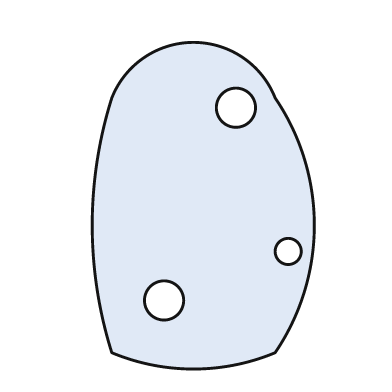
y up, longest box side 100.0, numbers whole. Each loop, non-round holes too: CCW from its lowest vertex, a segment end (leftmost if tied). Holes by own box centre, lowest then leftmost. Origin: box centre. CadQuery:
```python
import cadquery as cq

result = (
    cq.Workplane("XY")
    .moveTo(-28.0, -45.0)
    .threePointArc((-3.0, -50.0), (22.0, -45.0))
    .threePointArc((34.0, -6.0), (22.0, 33.0))
    .threePointArc((-3.0, 50.0), (-28.0, 33.0))
    .threePointArc((-34.0, -6.0), (-28.0, -45.0))
    .close()
    .moveTo(-12.0, -29.0)
    .circle(6.0)
    .moveTo(26.0, -14.0)
    .circle(4.0)
    .moveTo(10.0, 30.0)
    .circle(6.0)
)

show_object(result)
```